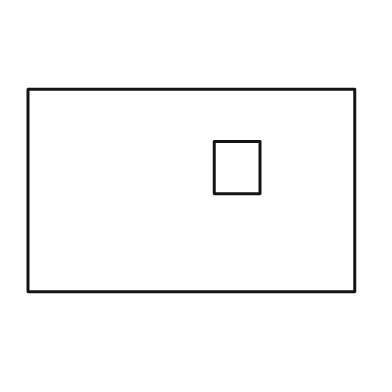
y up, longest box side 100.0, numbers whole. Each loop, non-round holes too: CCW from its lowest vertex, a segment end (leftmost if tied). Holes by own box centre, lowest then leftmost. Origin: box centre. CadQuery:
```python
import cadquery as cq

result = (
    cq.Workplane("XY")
    .moveTo(-50.0, -31.0)
    .lineTo(50.0, -31.0)
    .lineTo(50.0, 31.0)
    .lineTo(-50.0, 31.0)
    .close()
    .moveTo(7.0, -1.0)
    .lineTo(21.0, -1.0)
    .lineTo(21.0, 15.0)
    .lineTo(7.0, 15.0)
    .close()
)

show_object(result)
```